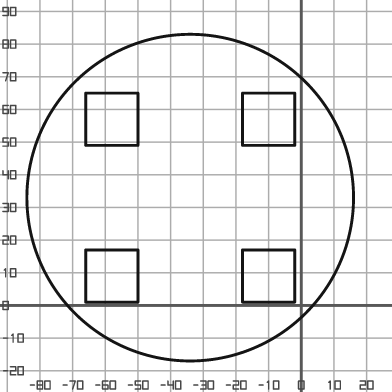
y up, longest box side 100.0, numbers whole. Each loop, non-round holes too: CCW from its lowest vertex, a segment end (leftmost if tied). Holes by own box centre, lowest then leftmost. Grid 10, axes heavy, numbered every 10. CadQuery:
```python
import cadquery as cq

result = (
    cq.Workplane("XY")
    .moveTo(-34.0, 33.0)
    .circle(50.0)
    .moveTo(-66.0, 1.0)
    .lineTo(-50.0, 1.0)
    .lineTo(-50.0, 17.0)
    .lineTo(-66.0, 17.0)
    .close()
    .moveTo(-18.0, 1.0)
    .lineTo(-2.0, 1.0)
    .lineTo(-2.0, 17.0)
    .lineTo(-18.0, 17.0)
    .close()
    .moveTo(-66.0, 49.0)
    .lineTo(-50.0, 49.0)
    .lineTo(-50.0, 65.0)
    .lineTo(-66.0, 65.0)
    .close()
    .moveTo(-18.0, 49.0)
    .lineTo(-2.0, 49.0)
    .lineTo(-2.0, 65.0)
    .lineTo(-18.0, 65.0)
    .close()
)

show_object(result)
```